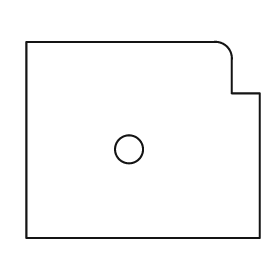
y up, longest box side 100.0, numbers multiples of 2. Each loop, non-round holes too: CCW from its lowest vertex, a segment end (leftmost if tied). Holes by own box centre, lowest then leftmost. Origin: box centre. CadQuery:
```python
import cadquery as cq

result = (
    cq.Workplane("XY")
    .moveTo(-50.0, -42.0)
    .lineTo(50.0, -42.0)
    .lineTo(50.0, 20.0)
    .lineTo(38.0, 20.0)
    .lineTo(38.0, 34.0)
    .threePointArc((36.0, 40.0), (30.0, 42.0))
    .lineTo(-50.0, 42.0)
    .close()
    .moveTo(-6.0, -4.0)
    .circle(6.0)
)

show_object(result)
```